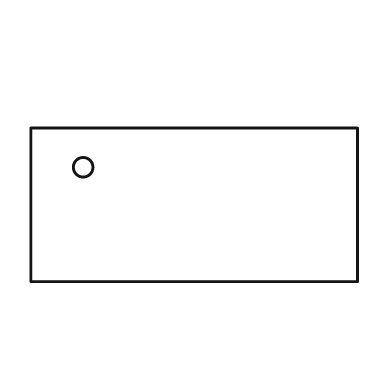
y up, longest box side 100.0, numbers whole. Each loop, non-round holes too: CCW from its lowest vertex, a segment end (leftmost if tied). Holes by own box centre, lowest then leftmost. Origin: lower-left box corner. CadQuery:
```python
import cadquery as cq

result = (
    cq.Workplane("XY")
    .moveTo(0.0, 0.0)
    .lineTo(100.0, 0.0)
    .lineTo(100.0, 47.0)
    .lineTo(0.0, 47.0)
    .close()
    .moveTo(16.0, 35.0)
    .circle(3.0)
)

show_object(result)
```